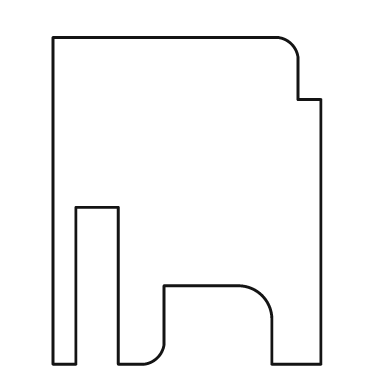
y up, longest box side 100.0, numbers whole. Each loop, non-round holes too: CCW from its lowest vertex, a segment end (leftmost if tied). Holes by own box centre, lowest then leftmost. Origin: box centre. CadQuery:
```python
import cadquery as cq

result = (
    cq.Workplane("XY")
    .moveTo(-41.0, -50.0)
    .lineTo(-34.0, -50.0)
    .lineTo(-34.0, -2.0)
    .lineTo(-21.0, -2.0)
    .lineTo(-21.0, -50.0)
    .lineTo(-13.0, -50.0)
    .threePointArc((-9.0, -48.0), (-7.0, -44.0))
    .lineTo(-7.0, -26.0)
    .lineTo(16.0, -26.0)
    .threePointArc((23.0, -29.0), (26.0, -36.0))
    .lineTo(26.0, -50.0)
    .lineTo(41.0, -50.0)
    .lineTo(41.0, 31.0)
    .lineTo(34.0, 31.0)
    .lineTo(34.0, 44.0)
    .threePointArc((32.0, 48.0), (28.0, 50.0))
    .lineTo(-41.0, 50.0)
    .close()
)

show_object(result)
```